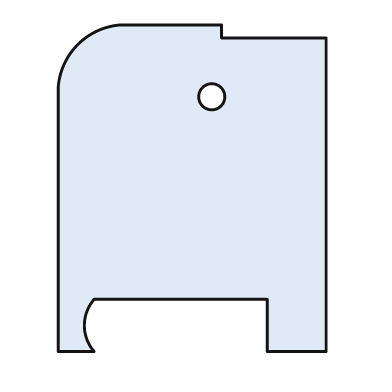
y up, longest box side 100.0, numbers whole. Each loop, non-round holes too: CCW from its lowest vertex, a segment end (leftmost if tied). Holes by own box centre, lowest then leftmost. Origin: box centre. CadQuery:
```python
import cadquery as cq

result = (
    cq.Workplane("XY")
    .moveTo(-41.0, -50.0)
    .lineTo(-30.0, -50.0)
    .threePointArc((-33.0, -42.0), (-30.0, -34.0))
    .lineTo(23.0, -34.0)
    .lineTo(23.0, -50.0)
    .lineTo(41.0, -50.0)
    .lineTo(41.0, 46.0)
    .lineTo(9.0, 46.0)
    .lineTo(9.0, 50.0)
    .lineTo(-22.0, 50.0)
    .threePointArc((-35.0, 44.0), (-41.0, 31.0))
    .close()
    .moveTo(6.0, 28.0)
    .circle(4.0)
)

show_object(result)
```